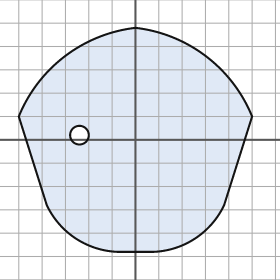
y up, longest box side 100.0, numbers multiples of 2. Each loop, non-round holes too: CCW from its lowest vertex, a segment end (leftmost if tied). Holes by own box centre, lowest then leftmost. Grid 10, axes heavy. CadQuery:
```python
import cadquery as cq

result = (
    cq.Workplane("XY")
    .moveTo(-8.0, -48.0)
    .lineTo(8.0, -48.0)
    .threePointArc((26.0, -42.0), (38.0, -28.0))
    .lineTo(50.0, 10.0)
    .threePointArc((30.0, 36.0), (0.0, 48.0))
    .threePointArc((-30.0, 36.0), (-50.0, 10.0))
    .lineTo(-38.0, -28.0)
    .threePointArc((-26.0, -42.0), (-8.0, -48.0))
    .close()
    .moveTo(-24.0, 2.0)
    .circle(4.0)
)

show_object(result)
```